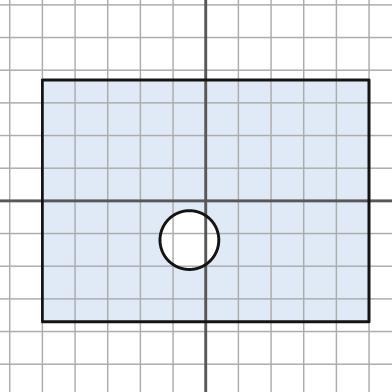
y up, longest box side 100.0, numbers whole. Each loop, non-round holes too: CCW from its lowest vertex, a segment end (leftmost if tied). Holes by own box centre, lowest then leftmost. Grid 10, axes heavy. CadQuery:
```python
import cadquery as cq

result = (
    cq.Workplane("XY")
    .moveTo(-50.0, -37.0)
    .lineTo(50.0, -37.0)
    .lineTo(50.0, 37.0)
    .lineTo(-50.0, 37.0)
    .close()
    .moveTo(-5.0, -12.0)
    .circle(9.0)
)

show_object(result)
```